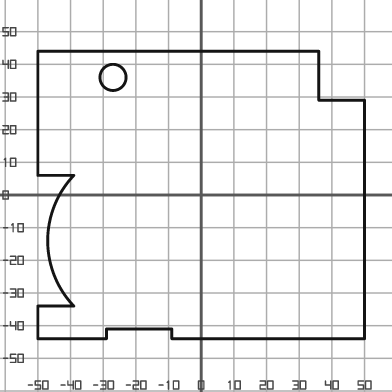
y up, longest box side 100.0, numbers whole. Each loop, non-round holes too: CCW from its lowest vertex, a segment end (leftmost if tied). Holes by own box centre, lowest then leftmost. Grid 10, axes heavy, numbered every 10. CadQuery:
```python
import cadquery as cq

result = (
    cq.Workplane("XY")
    .moveTo(-50.0, -44.0)
    .lineTo(-29.0, -44.0)
    .lineTo(-29.0, -41.0)
    .lineTo(-9.0, -41.0)
    .lineTo(-9.0, -44.0)
    .lineTo(50.0, -44.0)
    .lineTo(50.0, 29.0)
    .lineTo(36.0, 29.0)
    .lineTo(36.0, 44.0)
    .lineTo(-50.0, 44.0)
    .lineTo(-50.0, 6.0)
    .lineTo(-39.0, 6.0)
    .threePointArc((-47.0, -14.0), (-39.0, -34.0))
    .lineTo(-50.0, -34.0)
    .close()
    .moveTo(-27.0, 36.0)
    .circle(4.0)
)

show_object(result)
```